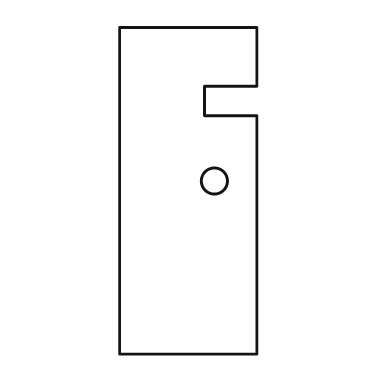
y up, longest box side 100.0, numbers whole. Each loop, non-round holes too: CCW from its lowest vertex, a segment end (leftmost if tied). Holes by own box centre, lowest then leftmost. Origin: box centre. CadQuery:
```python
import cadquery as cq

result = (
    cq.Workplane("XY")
    .moveTo(-21.0, -50.0)
    .lineTo(21.0, -50.0)
    .lineTo(21.0, 23.0)
    .lineTo(5.0, 23.0)
    .lineTo(5.0, 32.0)
    .lineTo(21.0, 32.0)
    .lineTo(21.0, 50.0)
    .lineTo(-21.0, 50.0)
    .close()
    .moveTo(8.0, 3.0)
    .circle(4.0)
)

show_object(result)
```